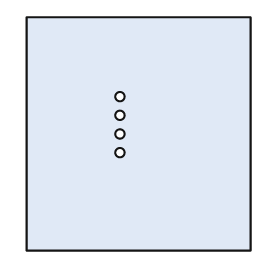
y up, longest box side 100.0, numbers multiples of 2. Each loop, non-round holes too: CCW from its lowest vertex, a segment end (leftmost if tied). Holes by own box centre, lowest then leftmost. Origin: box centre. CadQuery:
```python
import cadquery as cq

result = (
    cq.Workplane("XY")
    .moveTo(-48.0, -50.0)
    .lineTo(48.0, -50.0)
    .lineTo(48.0, 50.0)
    .lineTo(-48.0, 50.0)
    .close()
    .moveTo(-8.0, -8.0)
    .circle(2.0)
    .moveTo(-8.0, 0.0)
    .circle(2.0)
    .moveTo(-8.0, 8.0)
    .circle(2.0)
    .moveTo(-8.0, 16.0)
    .circle(2.0)
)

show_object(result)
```